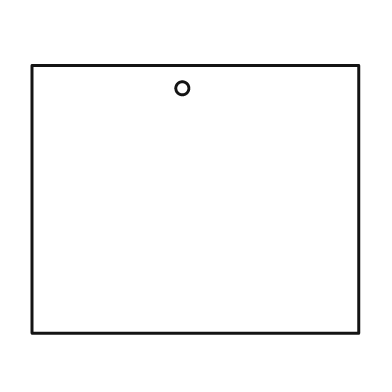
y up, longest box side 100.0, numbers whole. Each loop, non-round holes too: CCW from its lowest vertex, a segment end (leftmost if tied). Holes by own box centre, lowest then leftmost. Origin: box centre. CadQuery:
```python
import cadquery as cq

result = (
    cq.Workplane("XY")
    .moveTo(-50.0, -41.0)
    .lineTo(50.0, -41.0)
    .lineTo(50.0, 41.0)
    .lineTo(-50.0, 41.0)
    .close()
    .moveTo(-4.0, 34.0)
    .circle(2.0)
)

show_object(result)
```